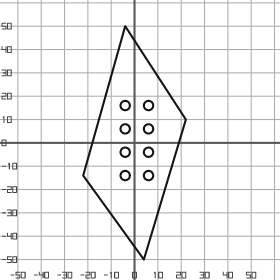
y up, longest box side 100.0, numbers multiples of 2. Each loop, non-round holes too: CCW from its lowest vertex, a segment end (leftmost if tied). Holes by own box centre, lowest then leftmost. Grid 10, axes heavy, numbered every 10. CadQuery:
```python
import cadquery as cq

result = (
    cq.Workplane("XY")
    .moveTo(4.0, -50.0)
    .lineTo(22.0, 10.0)
    .lineTo(-4.0, 50.0)
    .lineTo(-22.0, -14.0)
    .close()
    .moveTo(-4.0, -14.0)
    .circle(2.0)
    .moveTo(6.0, -14.0)
    .circle(2.0)
    .moveTo(-4.0, -4.0)
    .circle(2.0)
    .moveTo(6.0, -4.0)
    .circle(2.0)
    .moveTo(-4.0, 6.0)
    .circle(2.0)
    .moveTo(6.0, 6.0)
    .circle(2.0)
    .moveTo(-4.0, 16.0)
    .circle(2.0)
    .moveTo(6.0, 16.0)
    .circle(2.0)
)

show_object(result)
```